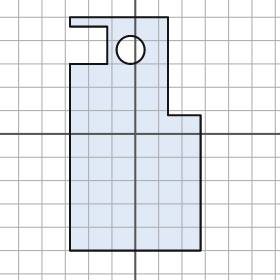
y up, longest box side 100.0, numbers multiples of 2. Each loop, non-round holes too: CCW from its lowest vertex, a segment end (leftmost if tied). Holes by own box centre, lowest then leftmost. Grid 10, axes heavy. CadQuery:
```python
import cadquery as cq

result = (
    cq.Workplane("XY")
    .moveTo(-28.0, -50.0)
    .lineTo(28.0, -50.0)
    .lineTo(28.0, 8.0)
    .lineTo(14.0, 8.0)
    .lineTo(14.0, 50.0)
    .lineTo(-28.0, 50.0)
    .lineTo(-28.0, 46.0)
    .lineTo(-12.0, 46.0)
    .lineTo(-12.0, 30.0)
    .lineTo(-28.0, 30.0)
    .close()
    .moveTo(-2.0, 36.0)
    .circle(6.0)
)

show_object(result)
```